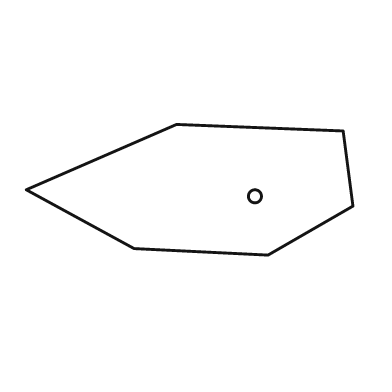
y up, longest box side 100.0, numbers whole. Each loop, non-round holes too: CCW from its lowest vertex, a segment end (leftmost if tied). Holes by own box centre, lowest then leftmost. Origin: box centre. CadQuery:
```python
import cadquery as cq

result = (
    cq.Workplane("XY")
    .moveTo(24.0, -20.0)
    .lineTo(50.0, -5.0)
    .lineTo(47.0, 18.0)
    .lineTo(-4.0, 20.0)
    .lineTo(-50.0, 0.0)
    .lineTo(-17.0, -18.0)
    .close()
    .moveTo(20.0, -2.0)
    .circle(2.0)
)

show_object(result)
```